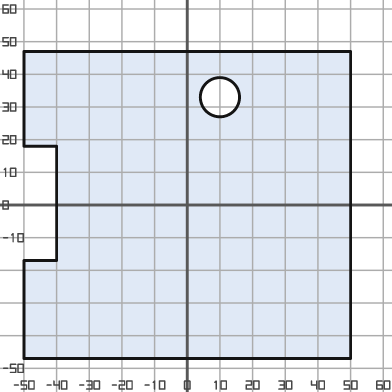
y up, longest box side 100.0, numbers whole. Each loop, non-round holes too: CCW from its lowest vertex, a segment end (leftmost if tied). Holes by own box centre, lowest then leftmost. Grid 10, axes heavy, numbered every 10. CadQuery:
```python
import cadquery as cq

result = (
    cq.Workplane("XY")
    .moveTo(-50.0, -47.0)
    .lineTo(50.0, -47.0)
    .lineTo(50.0, 47.0)
    .lineTo(-50.0, 47.0)
    .lineTo(-50.0, 18.0)
    .lineTo(-40.0, 18.0)
    .lineTo(-40.0, -17.0)
    .lineTo(-50.0, -17.0)
    .close()
    .moveTo(10.0, 33.0)
    .circle(6.0)
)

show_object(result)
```